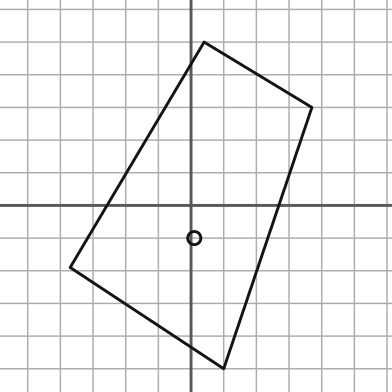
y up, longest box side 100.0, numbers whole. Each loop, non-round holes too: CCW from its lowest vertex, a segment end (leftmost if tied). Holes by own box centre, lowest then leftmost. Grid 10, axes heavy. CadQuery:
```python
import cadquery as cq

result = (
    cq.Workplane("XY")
    .moveTo(10.0, -50.0)
    .lineTo(37.0, 30.0)
    .lineTo(4.0, 50.0)
    .lineTo(-37.0, -19.0)
    .close()
    .moveTo(1.0, -10.0)
    .circle(2.0)
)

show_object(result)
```